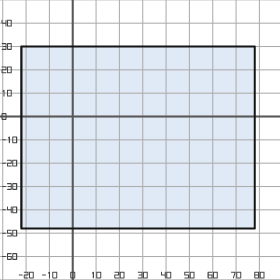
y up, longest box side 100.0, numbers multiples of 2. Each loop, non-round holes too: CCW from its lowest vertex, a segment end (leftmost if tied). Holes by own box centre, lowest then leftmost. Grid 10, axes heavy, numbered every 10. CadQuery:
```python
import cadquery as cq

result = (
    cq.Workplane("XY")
    .moveTo(-22.0, -48.0)
    .lineTo(78.0, -48.0)
    .lineTo(78.0, 30.0)
    .lineTo(-22.0, 30.0)
    .close()
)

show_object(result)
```